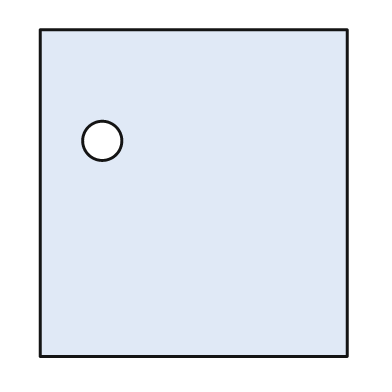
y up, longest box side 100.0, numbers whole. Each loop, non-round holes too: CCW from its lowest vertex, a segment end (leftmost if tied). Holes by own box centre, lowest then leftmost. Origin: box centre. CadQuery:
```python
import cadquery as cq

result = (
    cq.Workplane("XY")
    .moveTo(-47.0, -50.0)
    .lineTo(47.0, -50.0)
    .lineTo(47.0, 50.0)
    .lineTo(-47.0, 50.0)
    .close()
    .moveTo(-28.0, 16.0)
    .circle(6.0)
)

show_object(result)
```